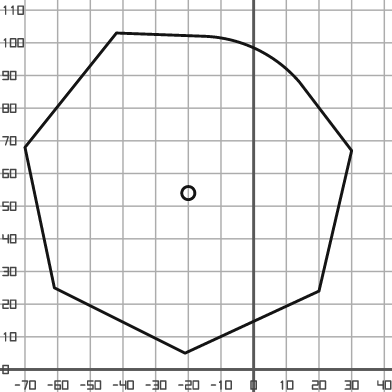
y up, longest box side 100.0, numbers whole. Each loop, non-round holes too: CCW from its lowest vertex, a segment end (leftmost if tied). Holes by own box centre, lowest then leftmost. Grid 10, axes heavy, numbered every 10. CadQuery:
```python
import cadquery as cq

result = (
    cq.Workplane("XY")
    .moveTo(-21.0, 5.0)
    .lineTo(20.0, 24.0)
    .lineTo(30.0, 67.0)
    .lineTo(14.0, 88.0)
    .threePointArc((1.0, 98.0), (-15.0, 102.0))
    .lineTo(-42.0, 103.0)
    .lineTo(-70.0, 68.0)
    .lineTo(-61.0, 25.0)
    .close()
    .moveTo(-20.0, 54.0)
    .circle(2.0)
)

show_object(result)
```